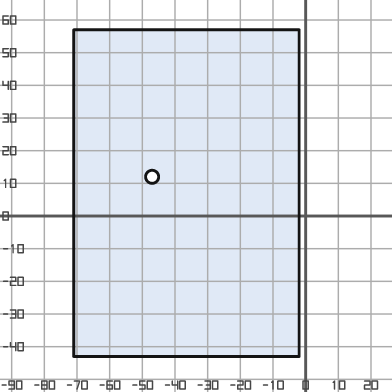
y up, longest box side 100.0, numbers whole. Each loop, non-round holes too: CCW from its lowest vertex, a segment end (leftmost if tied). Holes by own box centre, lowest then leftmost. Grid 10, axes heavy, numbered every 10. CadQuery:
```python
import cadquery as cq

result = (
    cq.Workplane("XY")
    .moveTo(-71.0, -43.0)
    .lineTo(-2.0, -43.0)
    .lineTo(-2.0, 57.0)
    .lineTo(-71.0, 57.0)
    .close()
    .moveTo(-47.0, 12.0)
    .circle(2.0)
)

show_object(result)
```